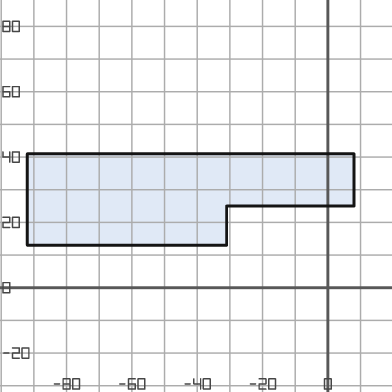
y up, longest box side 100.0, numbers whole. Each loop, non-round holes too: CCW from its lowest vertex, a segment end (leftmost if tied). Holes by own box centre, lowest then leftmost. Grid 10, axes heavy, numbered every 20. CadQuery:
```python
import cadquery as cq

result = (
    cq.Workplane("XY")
    .moveTo(-92.0, 13.0)
    .lineTo(-31.0, 13.0)
    .lineTo(-31.0, 25.0)
    .lineTo(8.0, 25.0)
    .lineTo(8.0, 41.0)
    .lineTo(-92.0, 41.0)
    .close()
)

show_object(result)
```